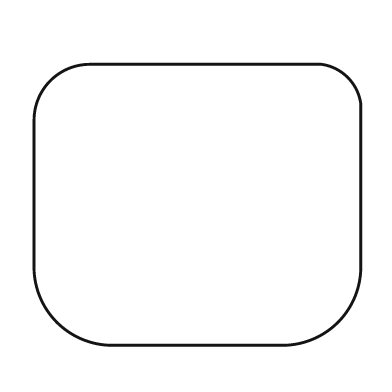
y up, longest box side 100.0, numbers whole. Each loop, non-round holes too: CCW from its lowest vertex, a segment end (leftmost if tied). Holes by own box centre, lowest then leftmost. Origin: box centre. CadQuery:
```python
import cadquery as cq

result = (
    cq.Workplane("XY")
    .moveTo(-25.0, -43.0)
    .lineTo(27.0, -43.0)
    .threePointArc((43.0, -36.0), (50.0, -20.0))
    .lineTo(50.0, 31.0)
    .threePointArc((46.0, 39.0), (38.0, 43.0))
    .lineTo(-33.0, 43.0)
    .threePointArc((-45.0, 38.0), (-50.0, 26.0))
    .lineTo(-50.0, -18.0)
    .threePointArc((-43.0, -36.0), (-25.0, -43.0))
    .close()
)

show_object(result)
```